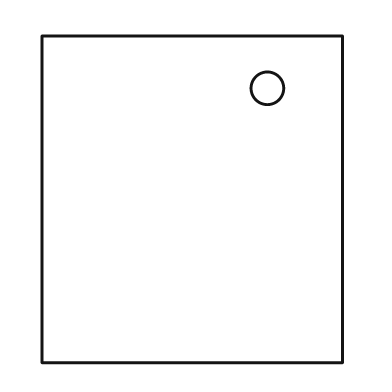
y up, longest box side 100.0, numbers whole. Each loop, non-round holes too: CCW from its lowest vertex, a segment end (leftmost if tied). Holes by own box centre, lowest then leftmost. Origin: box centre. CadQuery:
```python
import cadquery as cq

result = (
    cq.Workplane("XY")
    .moveTo(-46.0, -50.0)
    .lineTo(46.0, -50.0)
    .lineTo(46.0, 50.0)
    .lineTo(-46.0, 50.0)
    .close()
    .moveTo(23.0, 34.0)
    .circle(5.0)
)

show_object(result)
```